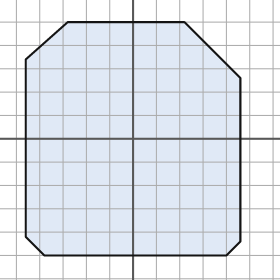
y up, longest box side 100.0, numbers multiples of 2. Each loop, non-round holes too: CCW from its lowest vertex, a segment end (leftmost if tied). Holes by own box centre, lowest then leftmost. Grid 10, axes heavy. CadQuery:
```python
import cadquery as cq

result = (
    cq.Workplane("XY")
    .moveTo(-38.0, -50.0)
    .lineTo(40.0, -50.0)
    .lineTo(46.0, -44.0)
    .lineTo(46.0, 26.0)
    .lineTo(22.0, 50.0)
    .lineTo(-28.0, 50.0)
    .lineTo(-46.0, 34.0)
    .lineTo(-46.0, -42.0)
    .close()
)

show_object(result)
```